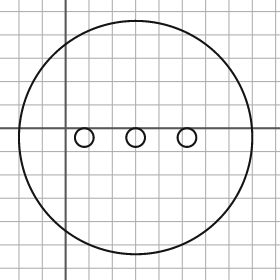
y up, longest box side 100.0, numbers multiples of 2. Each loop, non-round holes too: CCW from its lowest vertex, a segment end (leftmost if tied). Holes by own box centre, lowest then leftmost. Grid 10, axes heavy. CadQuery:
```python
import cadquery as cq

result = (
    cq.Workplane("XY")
    .moveTo(30.0, -4.0)
    .circle(50.0)
    .moveTo(8.0, -4.0)
    .circle(4.0)
    .moveTo(30.0, -4.0)
    .circle(4.0)
    .moveTo(52.0, -4.0)
    .circle(4.0)
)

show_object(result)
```